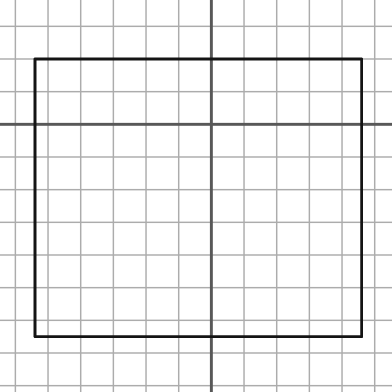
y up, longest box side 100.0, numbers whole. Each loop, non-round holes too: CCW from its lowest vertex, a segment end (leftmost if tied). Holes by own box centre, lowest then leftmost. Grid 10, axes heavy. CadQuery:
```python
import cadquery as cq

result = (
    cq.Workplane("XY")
    .moveTo(-54.0, -65.0)
    .lineTo(46.0, -65.0)
    .lineTo(46.0, 20.0)
    .lineTo(-54.0, 20.0)
    .close()
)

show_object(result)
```